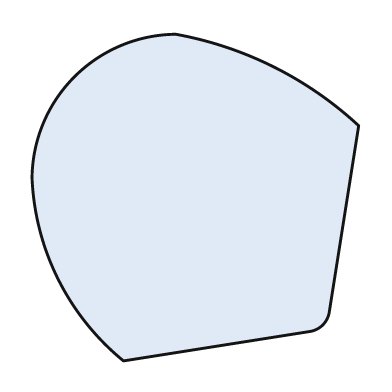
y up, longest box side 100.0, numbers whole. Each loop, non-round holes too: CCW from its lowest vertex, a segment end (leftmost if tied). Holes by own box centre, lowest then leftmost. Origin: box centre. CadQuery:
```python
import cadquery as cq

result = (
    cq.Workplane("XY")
    .moveTo(-22.0, -50.0)
    .lineTo(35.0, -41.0)
    .threePointArc((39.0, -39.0), (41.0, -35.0))
    .lineTo(50.0, 22.0)
    .threePointArc((24.0, 40.0), (-6.0, 50.0))
    .threePointArc((-37.0, 37.0), (-50.0, 6.0))
    .threePointArc((-42.0, -25.0), (-22.0, -50.0))
    .close()
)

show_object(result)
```